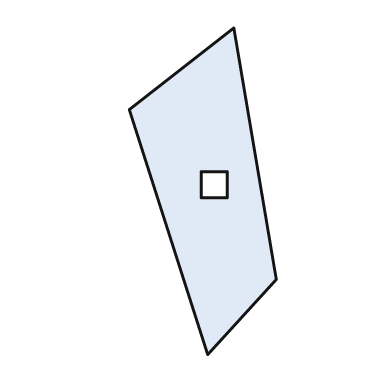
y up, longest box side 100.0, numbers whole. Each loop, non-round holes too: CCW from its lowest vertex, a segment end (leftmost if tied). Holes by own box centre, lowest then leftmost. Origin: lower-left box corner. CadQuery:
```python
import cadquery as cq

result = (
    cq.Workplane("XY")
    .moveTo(24.0, 0.0)
    .lineTo(45.0, 23.0)
    .lineTo(32.0, 100.0)
    .lineTo(0.0, 75.0)
    .close()
    .moveTo(22.0, 48.0)
    .lineTo(30.0, 48.0)
    .lineTo(30.0, 56.0)
    .lineTo(22.0, 56.0)
    .close()
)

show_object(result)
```